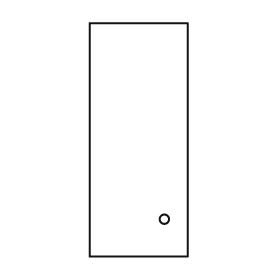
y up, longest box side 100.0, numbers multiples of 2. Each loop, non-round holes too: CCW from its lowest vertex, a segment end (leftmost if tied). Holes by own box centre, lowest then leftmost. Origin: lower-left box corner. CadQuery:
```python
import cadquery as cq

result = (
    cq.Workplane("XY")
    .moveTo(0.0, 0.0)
    .lineTo(42.0, 0.0)
    .lineTo(42.0, 100.0)
    .lineTo(0.0, 100.0)
    .close()
    .moveTo(32.0, 16.0)
    .circle(2.0)
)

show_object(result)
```